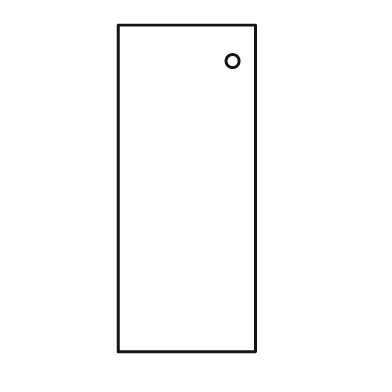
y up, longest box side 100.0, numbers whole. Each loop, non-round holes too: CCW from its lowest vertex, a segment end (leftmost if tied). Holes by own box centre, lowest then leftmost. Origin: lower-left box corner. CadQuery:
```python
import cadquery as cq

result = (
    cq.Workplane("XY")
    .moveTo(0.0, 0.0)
    .lineTo(42.0, 0.0)
    .lineTo(42.0, 100.0)
    .lineTo(0.0, 100.0)
    .close()
    .moveTo(35.0, 89.0)
    .circle(2.0)
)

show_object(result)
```